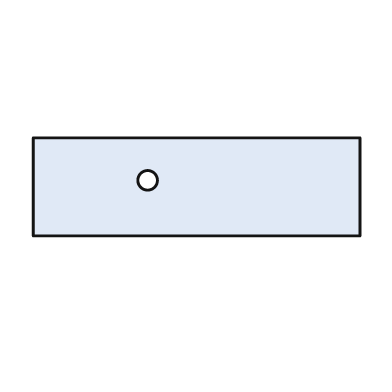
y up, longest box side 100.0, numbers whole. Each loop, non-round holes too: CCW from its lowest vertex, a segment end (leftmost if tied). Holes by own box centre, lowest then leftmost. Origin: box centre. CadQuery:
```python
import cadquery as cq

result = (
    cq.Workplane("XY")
    .moveTo(-50.0, -15.0)
    .lineTo(50.0, -15.0)
    .lineTo(50.0, 15.0)
    .lineTo(-50.0, 15.0)
    .close()
    .moveTo(-15.0, 2.0)
    .circle(3.0)
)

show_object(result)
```